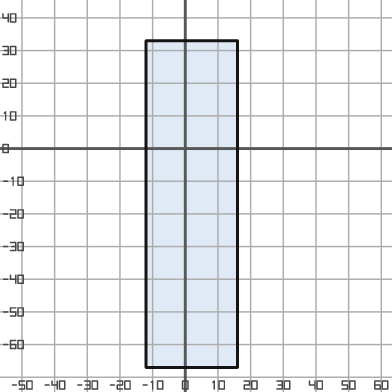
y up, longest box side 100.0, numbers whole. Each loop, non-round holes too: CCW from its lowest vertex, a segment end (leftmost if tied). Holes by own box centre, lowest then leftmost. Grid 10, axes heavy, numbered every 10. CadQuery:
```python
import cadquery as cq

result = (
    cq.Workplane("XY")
    .moveTo(-12.0, -67.0)
    .lineTo(16.0, -67.0)
    .lineTo(16.0, 33.0)
    .lineTo(-12.0, 33.0)
    .close()
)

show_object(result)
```